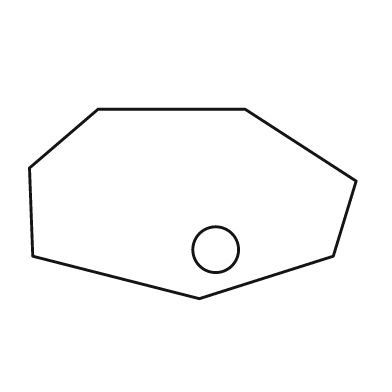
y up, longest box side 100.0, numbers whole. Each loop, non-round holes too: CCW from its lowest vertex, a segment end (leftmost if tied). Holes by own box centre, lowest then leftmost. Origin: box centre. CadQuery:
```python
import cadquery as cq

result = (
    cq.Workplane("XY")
    .moveTo(2.0, -29.0)
    .lineTo(43.0, -16.0)
    .lineTo(50.0, 7.0)
    .lineTo(16.0, 29.0)
    .lineTo(-29.0, 29.0)
    .lineTo(-50.0, 11.0)
    .lineTo(-49.0, -16.0)
    .close()
    .moveTo(7.0, -14.0)
    .circle(7.0)
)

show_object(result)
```